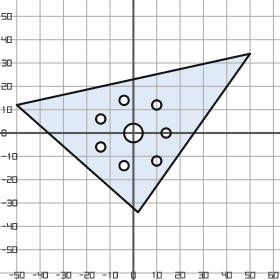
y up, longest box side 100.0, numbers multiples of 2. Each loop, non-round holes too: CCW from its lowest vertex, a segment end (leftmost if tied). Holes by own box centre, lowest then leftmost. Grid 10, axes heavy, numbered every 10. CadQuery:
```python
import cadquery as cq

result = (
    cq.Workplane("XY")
    .moveTo(2.0, -34.0)
    .lineTo(50.0, 34.0)
    .lineTo(-50.0, 12.0)
    .close()
    .moveTo(-4.0, -14.0)
    .circle(2.0)
    .moveTo(10.0, -12.0)
    .circle(2.0)
    .moveTo(-14.0, -6.0)
    .circle(2.0)
    .moveTo(0.0, 0.0)
    .circle(4.0)
    .moveTo(14.0, 0.0)
    .circle(2.0)
    .moveTo(-14.0, 6.0)
    .circle(2.0)
    .moveTo(10.0, 12.0)
    .circle(2.0)
    .moveTo(-4.0, 14.0)
    .circle(2.0)
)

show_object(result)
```